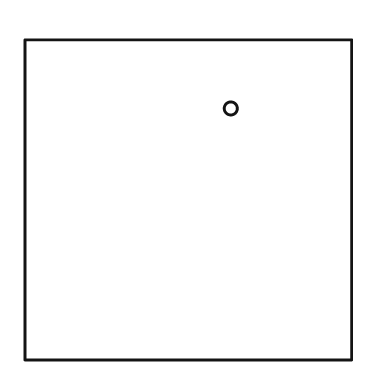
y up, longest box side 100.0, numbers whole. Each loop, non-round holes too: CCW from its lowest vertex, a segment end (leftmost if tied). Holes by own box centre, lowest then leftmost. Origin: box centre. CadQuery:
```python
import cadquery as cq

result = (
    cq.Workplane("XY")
    .moveTo(-50.0, -49.0)
    .lineTo(50.0, -49.0)
    .lineTo(50.0, 49.0)
    .lineTo(-50.0, 49.0)
    .close()
    .moveTo(13.0, 28.0)
    .circle(2.0)
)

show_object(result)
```